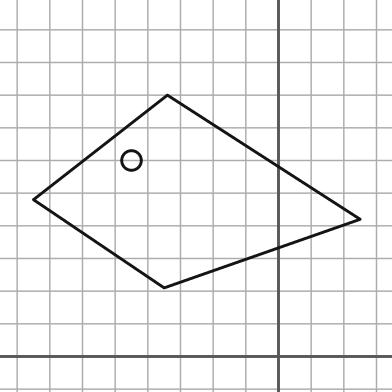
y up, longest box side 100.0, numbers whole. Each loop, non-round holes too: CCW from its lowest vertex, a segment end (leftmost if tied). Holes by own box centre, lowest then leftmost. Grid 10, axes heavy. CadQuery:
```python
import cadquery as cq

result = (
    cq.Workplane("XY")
    .moveTo(-35.0, 21.0)
    .lineTo(25.0, 42.0)
    .lineTo(-34.0, 80.0)
    .lineTo(-75.0, 48.0)
    .close()
    .moveTo(-45.0, 60.0)
    .circle(3.0)
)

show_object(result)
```